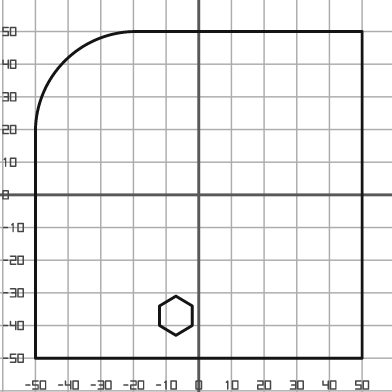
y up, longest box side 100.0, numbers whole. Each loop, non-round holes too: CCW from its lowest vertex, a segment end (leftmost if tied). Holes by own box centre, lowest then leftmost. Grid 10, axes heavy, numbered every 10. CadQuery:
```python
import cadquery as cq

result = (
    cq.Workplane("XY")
    .moveTo(-50.0, -50.0)
    .lineTo(50.0, -50.0)
    .lineTo(50.0, 50.0)
    .lineTo(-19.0, 50.0)
    .threePointArc((-41.0, 41.0), (-50.0, 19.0))
    .close()
    .moveTo(-7.0, -43.0)
    .lineTo(-2.0, -40.0)
    .lineTo(-2.0, -34.0)
    .lineTo(-7.0, -31.0)
    .lineTo(-12.0, -34.0)
    .lineTo(-12.0, -40.0)
    .close()
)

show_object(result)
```